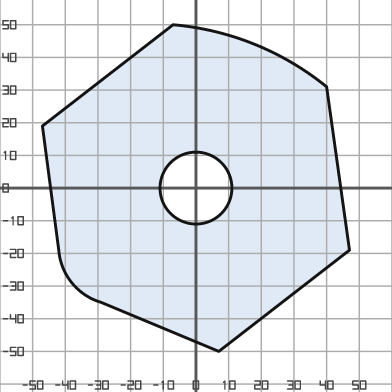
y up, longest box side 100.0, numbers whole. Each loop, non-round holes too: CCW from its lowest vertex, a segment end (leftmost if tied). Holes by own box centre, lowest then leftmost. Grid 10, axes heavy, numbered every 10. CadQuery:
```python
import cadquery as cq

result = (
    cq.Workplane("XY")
    .moveTo(7.0, -50.0)
    .lineTo(47.0, -19.0)
    .lineTo(40.0, 31.0)
    .threePointArc((18.0, 44.0), (-7.0, 50.0))
    .lineTo(-47.0, 19.0)
    .lineTo(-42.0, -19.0)
    .threePointArc((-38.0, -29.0), (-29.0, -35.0))
    .close()
    .moveTo(0.0, 0.0)
    .circle(11.0)
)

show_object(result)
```